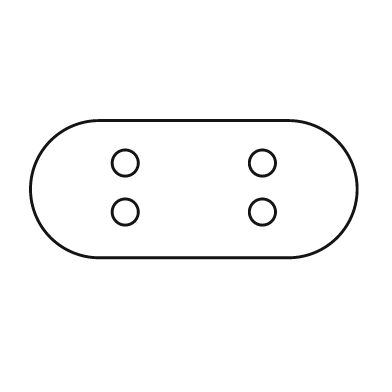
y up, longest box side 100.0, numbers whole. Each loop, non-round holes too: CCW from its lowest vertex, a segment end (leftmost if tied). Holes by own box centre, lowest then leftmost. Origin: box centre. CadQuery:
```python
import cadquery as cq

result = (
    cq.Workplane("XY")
    .moveTo(-29.0, -21.0)
    .lineTo(29.0, -21.0)
    .threePointArc((50.0, 0.0), (29.0, 21.0))
    .lineTo(-29.0, 21.0)
    .threePointArc((-50.0, 0.0), (-29.0, -21.0))
    .close()
    .moveTo(-21.0, -7.0)
    .circle(4.0)
    .moveTo(21.0, -7.0)
    .circle(4.0)
    .moveTo(-21.0, 8.0)
    .circle(4.0)
    .moveTo(21.0, 8.0)
    .circle(4.0)
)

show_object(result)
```